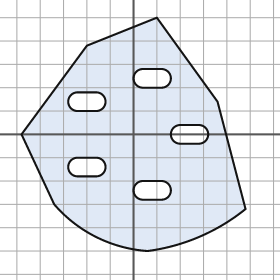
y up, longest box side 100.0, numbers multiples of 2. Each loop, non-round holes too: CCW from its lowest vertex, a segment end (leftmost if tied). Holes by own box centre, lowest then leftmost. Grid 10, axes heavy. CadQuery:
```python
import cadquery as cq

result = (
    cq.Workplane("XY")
    .moveTo(6.0, -50.0)
    .threePointArc((28.0, -44.0), (48.0, -32.0))
    .lineTo(36.0, 14.0)
    .lineTo(10.0, 50.0)
    .lineTo(-20.0, 38.0)
    .lineTo(-48.0, 0.0)
    .lineTo(-34.0, -30.0)
    .threePointArc((-16.0, -44.0), (6.0, -50.0))
    .close()
    .moveTo(4.0, -28.0)
    .lineTo(12.0, -28.0)
    .threePointArc((16.0, -24.0), (12.0, -20.0))
    .lineTo(4.0, -20.0)
    .threePointArc((0.0, -24.0), (4.0, -28.0))
    .close()
    .moveTo(-24.0, -18.0)
    .lineTo(-16.0, -18.0)
    .threePointArc((-12.0, -14.0), (-16.0, -10.0))
    .lineTo(-24.0, -10.0)
    .threePointArc((-28.0, -14.0), (-24.0, -18.0))
    .close()
    .moveTo(20.0, -4.0)
    .lineTo(28.0, -4.0)
    .threePointArc((32.0, 0.0), (28.0, 4.0))
    .lineTo(20.0, 4.0)
    .threePointArc((16.0, 0.0), (20.0, -4.0))
    .close()
    .moveTo(-24.0, 10.0)
    .lineTo(-16.0, 10.0)
    .threePointArc((-12.0, 14.0), (-16.0, 18.0))
    .lineTo(-24.0, 18.0)
    .threePointArc((-28.0, 14.0), (-24.0, 10.0))
    .close()
    .moveTo(4.0, 20.0)
    .lineTo(12.0, 20.0)
    .threePointArc((16.0, 24.0), (12.0, 28.0))
    .lineTo(4.0, 28.0)
    .threePointArc((0.0, 24.0), (4.0, 20.0))
    .close()
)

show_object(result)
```